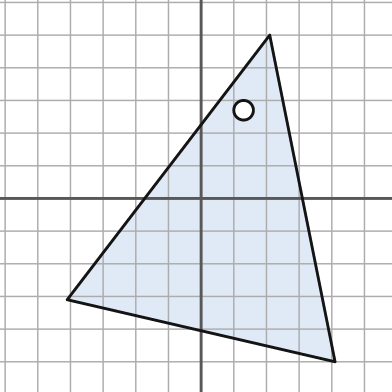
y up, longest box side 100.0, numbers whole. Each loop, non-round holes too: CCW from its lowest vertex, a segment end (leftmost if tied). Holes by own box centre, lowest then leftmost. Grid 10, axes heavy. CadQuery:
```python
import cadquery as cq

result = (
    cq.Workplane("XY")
    .moveTo(41.0, -50.0)
    .lineTo(21.0, 50.0)
    .lineTo(-41.0, -31.0)
    .close()
    .moveTo(13.0, 27.0)
    .circle(3.0)
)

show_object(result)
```